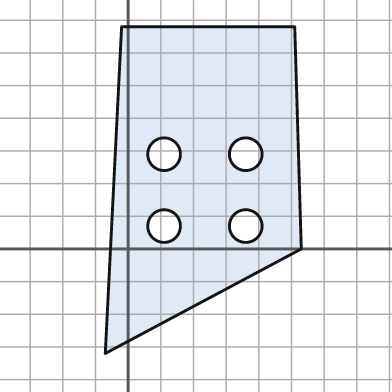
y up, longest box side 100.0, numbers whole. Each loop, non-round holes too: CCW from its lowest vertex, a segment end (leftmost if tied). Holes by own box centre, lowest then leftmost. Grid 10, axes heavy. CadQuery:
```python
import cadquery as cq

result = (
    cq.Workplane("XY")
    .moveTo(-7.0, -32.0)
    .lineTo(53.0, 0.0)
    .lineTo(51.0, 68.0)
    .lineTo(-2.0, 68.0)
    .close()
    .moveTo(11.0, 7.0)
    .circle(5.0)
    .moveTo(36.0, 7.0)
    .circle(5.0)
    .moveTo(11.0, 29.0)
    .circle(5.0)
    .moveTo(36.0, 29.0)
    .circle(5.0)
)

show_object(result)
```